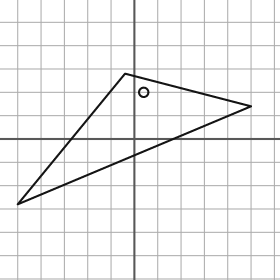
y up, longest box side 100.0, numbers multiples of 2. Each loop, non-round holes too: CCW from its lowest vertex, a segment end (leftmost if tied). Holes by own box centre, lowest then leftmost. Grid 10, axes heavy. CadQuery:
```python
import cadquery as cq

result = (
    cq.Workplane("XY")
    .moveTo(-50.0, -28.0)
    .lineTo(50.0, 14.0)
    .lineTo(-4.0, 28.0)
    .close()
    .moveTo(4.0, 20.0)
    .circle(2.0)
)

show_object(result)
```